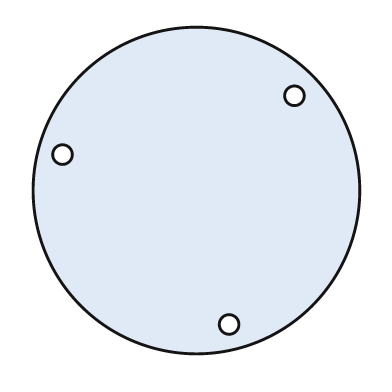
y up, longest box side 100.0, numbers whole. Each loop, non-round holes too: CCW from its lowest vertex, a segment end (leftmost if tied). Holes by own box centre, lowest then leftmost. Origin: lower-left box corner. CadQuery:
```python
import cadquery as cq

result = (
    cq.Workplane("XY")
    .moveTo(50.0, 50.0)
    .circle(50.0)
    .moveTo(60.0, 9.0)
    .circle(3.0)
    .moveTo(9.0, 61.0)
    .circle(3.0)
    .moveTo(80.0, 79.0)
    .circle(3.0)
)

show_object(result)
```